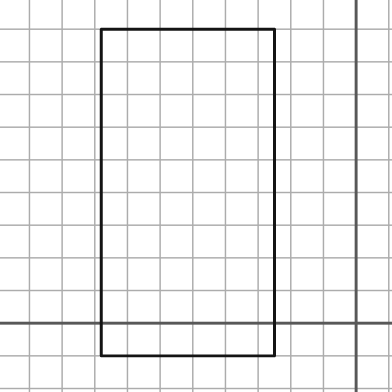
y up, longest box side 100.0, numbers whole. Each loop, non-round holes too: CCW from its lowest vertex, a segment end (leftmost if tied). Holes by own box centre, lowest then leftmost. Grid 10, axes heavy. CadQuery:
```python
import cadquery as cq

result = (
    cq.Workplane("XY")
    .moveTo(-78.0, -10.0)
    .lineTo(-25.0, -10.0)
    .lineTo(-25.0, 90.0)
    .lineTo(-78.0, 90.0)
    .close()
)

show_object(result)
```